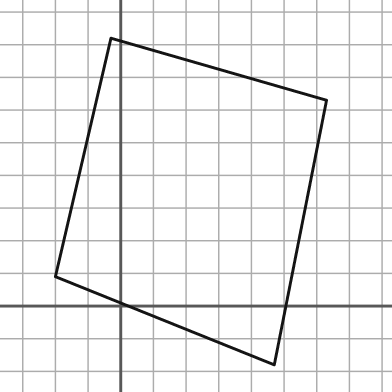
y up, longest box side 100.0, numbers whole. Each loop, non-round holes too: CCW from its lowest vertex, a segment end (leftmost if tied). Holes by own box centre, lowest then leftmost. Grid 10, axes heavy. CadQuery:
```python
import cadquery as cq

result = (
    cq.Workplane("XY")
    .moveTo(47.0, -18.0)
    .lineTo(63.0, 63.0)
    .lineTo(-3.0, 82.0)
    .lineTo(-20.0, 9.0)
    .close()
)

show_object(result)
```